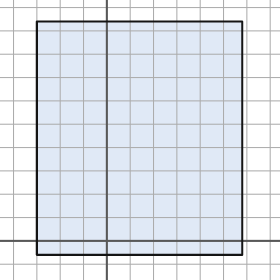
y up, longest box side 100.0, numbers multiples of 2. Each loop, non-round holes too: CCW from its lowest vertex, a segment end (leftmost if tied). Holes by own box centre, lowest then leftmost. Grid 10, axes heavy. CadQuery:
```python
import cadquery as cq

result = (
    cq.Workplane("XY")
    .moveTo(-30.0, -6.0)
    .lineTo(58.0, -6.0)
    .lineTo(58.0, 94.0)
    .lineTo(-30.0, 94.0)
    .close()
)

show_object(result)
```